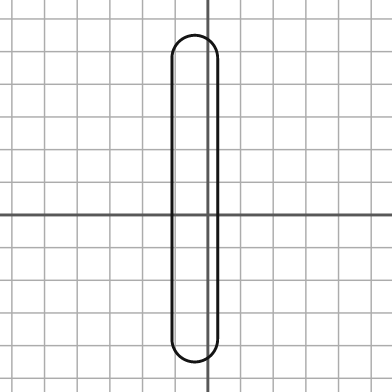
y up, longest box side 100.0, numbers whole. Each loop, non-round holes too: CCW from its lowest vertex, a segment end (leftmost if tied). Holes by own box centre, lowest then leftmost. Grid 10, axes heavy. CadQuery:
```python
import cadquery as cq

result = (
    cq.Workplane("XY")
    .moveTo(-11.0, -38.0)
    .threePointArc((-4.0, -45.0), (3.0, -38.0))
    .lineTo(3.0, 48.0)
    .threePointArc((-4.0, 55.0), (-11.0, 48.0))
    .close()
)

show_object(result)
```